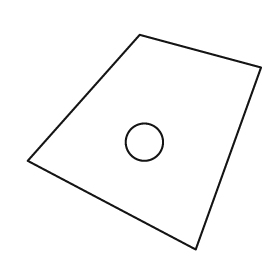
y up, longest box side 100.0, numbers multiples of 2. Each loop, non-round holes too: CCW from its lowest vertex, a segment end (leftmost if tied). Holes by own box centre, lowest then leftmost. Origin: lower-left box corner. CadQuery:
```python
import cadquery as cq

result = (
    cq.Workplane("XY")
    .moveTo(72.0, 0.0)
    .lineTo(100.0, 78.0)
    .lineTo(48.0, 92.0)
    .lineTo(0.0, 38.0)
    .close()
    .moveTo(50.0, 46.0)
    .circle(8.0)
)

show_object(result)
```